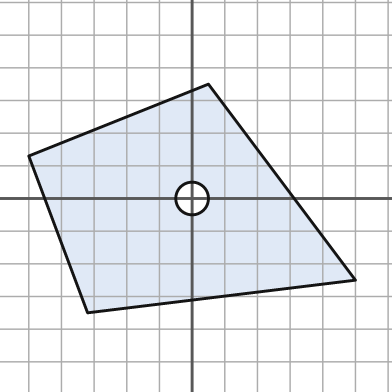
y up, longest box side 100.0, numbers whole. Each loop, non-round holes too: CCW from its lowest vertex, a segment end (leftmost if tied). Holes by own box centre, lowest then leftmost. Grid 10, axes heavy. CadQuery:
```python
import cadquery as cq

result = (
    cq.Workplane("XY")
    .moveTo(-32.0, -35.0)
    .lineTo(50.0, -25.0)
    .lineTo(5.0, 35.0)
    .lineTo(-50.0, 13.0)
    .close()
    .moveTo(0.0, 0.0)
    .circle(5.0)
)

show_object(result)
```